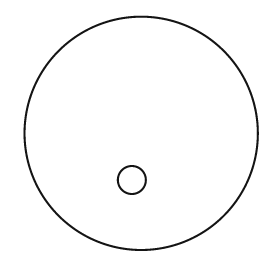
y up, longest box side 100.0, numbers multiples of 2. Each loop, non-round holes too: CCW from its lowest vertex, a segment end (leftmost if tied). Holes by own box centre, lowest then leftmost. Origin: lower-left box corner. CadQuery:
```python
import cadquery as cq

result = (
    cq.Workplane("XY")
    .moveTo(50.0, 50.0)
    .circle(50.0)
    .moveTo(46.0, 30.0)
    .circle(6.0)
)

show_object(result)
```